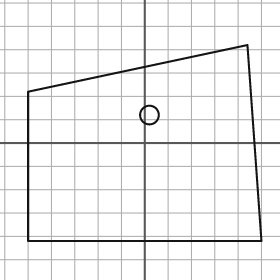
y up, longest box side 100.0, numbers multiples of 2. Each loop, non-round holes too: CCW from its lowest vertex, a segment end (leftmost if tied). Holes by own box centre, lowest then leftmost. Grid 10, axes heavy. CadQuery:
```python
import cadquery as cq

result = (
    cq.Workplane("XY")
    .moveTo(-50.0, -42.0)
    .lineTo(50.0, -42.0)
    .lineTo(44.0, 42.0)
    .lineTo(-50.0, 22.0)
    .close()
    .moveTo(2.0, 12.0)
    .circle(4.0)
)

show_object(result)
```